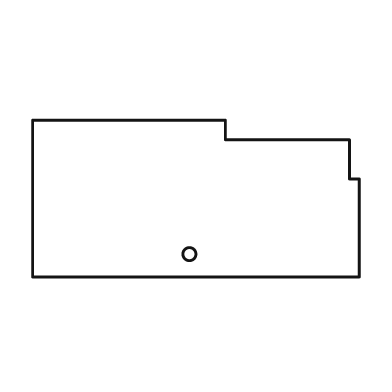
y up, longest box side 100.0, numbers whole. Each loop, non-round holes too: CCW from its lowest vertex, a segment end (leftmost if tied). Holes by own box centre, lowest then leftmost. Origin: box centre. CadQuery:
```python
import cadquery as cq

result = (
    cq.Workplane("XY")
    .moveTo(-50.0, -24.0)
    .lineTo(50.0, -24.0)
    .lineTo(50.0, 6.0)
    .lineTo(47.0, 6.0)
    .lineTo(47.0, 18.0)
    .lineTo(9.0, 18.0)
    .lineTo(9.0, 24.0)
    .lineTo(-50.0, 24.0)
    .close()
    .moveTo(-2.0, -17.0)
    .circle(2.0)
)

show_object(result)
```